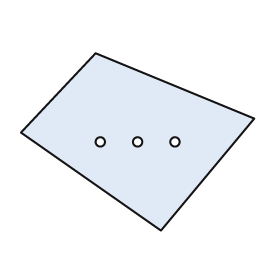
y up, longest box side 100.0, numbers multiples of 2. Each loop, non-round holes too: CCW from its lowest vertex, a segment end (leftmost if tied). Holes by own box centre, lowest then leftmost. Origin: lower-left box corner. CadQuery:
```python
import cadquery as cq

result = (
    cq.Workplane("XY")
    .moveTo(60.0, 0.0)
    .lineTo(100.0, 48.0)
    .lineTo(32.0, 76.0)
    .lineTo(0.0, 42.0)
    .close()
    .moveTo(34.0, 38.0)
    .circle(2.0)
    .moveTo(50.0, 38.0)
    .circle(2.0)
    .moveTo(66.0, 38.0)
    .circle(2.0)
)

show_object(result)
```